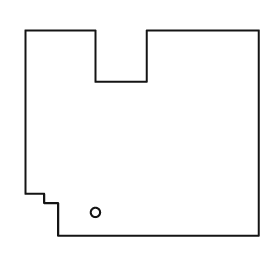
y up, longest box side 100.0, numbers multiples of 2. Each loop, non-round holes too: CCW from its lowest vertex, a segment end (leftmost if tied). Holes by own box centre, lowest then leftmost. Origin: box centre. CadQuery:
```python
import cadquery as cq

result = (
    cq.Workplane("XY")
    .moveTo(-36.0, -44.0)
    .lineTo(50.0, -44.0)
    .lineTo(50.0, 44.0)
    .lineTo(2.0, 44.0)
    .lineTo(2.0, 22.0)
    .lineTo(-20.0, 22.0)
    .lineTo(-20.0, 44.0)
    .lineTo(-50.0, 44.0)
    .lineTo(-50.0, -26.0)
    .lineTo(-42.0, -26.0)
    .lineTo(-42.0, -30.0)
    .lineTo(-36.0, -30.0)
    .close()
    .moveTo(-20.0, -34.0)
    .circle(2.0)
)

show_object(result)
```